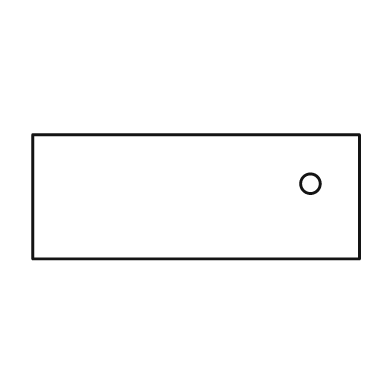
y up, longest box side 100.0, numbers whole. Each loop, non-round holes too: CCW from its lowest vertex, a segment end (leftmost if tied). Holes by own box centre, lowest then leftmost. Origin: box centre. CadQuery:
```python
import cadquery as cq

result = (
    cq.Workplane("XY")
    .moveTo(-50.0, -19.0)
    .lineTo(50.0, -19.0)
    .lineTo(50.0, 19.0)
    .lineTo(-50.0, 19.0)
    .close()
    .moveTo(35.0, 4.0)
    .circle(3.0)
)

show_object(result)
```